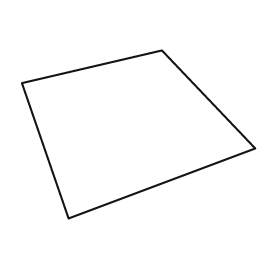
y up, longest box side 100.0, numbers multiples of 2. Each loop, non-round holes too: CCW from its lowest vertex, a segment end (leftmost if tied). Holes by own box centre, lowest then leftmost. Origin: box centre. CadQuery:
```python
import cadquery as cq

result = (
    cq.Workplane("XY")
    .moveTo(-30.0, -36.0)
    .lineTo(50.0, -6.0)
    .lineTo(10.0, 36.0)
    .lineTo(-50.0, 22.0)
    .close()
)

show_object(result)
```